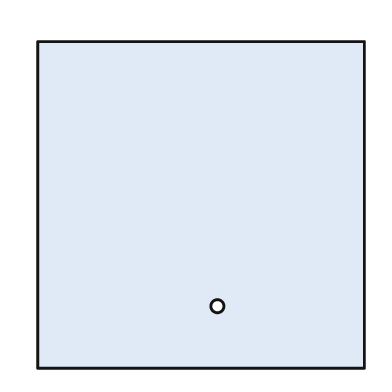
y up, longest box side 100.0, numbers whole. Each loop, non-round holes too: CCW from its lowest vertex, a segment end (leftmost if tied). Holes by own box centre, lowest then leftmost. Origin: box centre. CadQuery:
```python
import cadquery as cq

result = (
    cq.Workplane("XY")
    .moveTo(-50.0, -50.0)
    .lineTo(50.0, -50.0)
    .lineTo(50.0, 50.0)
    .lineTo(-50.0, 50.0)
    .close()
    .moveTo(5.0, -31.0)
    .circle(2.0)
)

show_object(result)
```